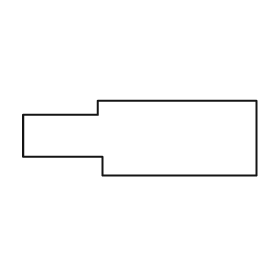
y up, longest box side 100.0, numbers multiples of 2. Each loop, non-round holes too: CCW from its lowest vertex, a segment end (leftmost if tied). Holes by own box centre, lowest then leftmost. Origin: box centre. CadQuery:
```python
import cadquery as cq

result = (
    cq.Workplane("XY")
    .moveTo(-16.0, -16.0)
    .lineTo(50.0, -16.0)
    .lineTo(50.0, 16.0)
    .lineTo(-18.0, 16.0)
    .lineTo(-18.0, 10.0)
    .lineTo(-50.0, 10.0)
    .lineTo(-50.0, -8.0)
    .lineTo(-16.0, -8.0)
    .close()
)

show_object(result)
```